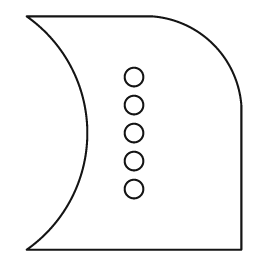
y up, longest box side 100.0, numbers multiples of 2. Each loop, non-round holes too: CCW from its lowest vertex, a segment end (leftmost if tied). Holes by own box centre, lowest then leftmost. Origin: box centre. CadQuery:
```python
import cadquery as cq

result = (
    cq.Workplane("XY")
    .moveTo(-46.0, -50.0)
    .lineTo(46.0, -50.0)
    .lineTo(46.0, 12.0)
    .threePointArc((34.0, 38.0), (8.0, 50.0))
    .lineTo(-46.0, 50.0)
    .threePointArc((-20.0, 0.0), (-46.0, -50.0))
    .close()
    .moveTo(0.0, -24.0)
    .circle(4.0)
    .moveTo(0.0, -12.0)
    .circle(4.0)
    .moveTo(0.0, 0.0)
    .circle(4.0)
    .moveTo(0.0, 12.0)
    .circle(4.0)
    .moveTo(0.0, 24.0)
    .circle(4.0)
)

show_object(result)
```